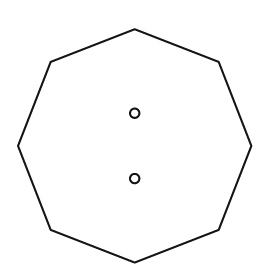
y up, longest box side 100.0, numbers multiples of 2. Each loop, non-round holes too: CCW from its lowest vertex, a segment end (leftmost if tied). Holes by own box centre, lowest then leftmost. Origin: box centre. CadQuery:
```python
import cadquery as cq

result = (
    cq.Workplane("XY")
    .moveTo(0.0, -50.0)
    .lineTo(36.0, -36.0)
    .lineTo(50.0, 0.0)
    .lineTo(36.0, 36.0)
    .lineTo(0.0, 50.0)
    .lineTo(-36.0, 36.0)
    .lineTo(-50.0, 0.0)
    .lineTo(-36.0, -36.0)
    .close()
    .moveTo(0.0, -14.0)
    .circle(2.0)
    .moveTo(0.0, 14.0)
    .circle(2.0)
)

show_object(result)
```